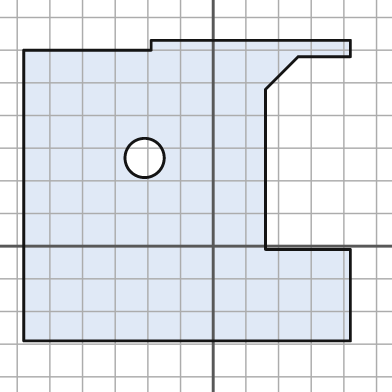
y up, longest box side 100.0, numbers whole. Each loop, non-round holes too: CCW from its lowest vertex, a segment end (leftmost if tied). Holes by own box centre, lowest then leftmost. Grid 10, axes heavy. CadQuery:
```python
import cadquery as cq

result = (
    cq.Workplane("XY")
    .moveTo(-58.0, -29.0)
    .lineTo(42.0, -29.0)
    .lineTo(42.0, -1.0)
    .lineTo(16.0, -1.0)
    .lineTo(16.0, 48.0)
    .lineTo(26.0, 58.0)
    .lineTo(42.0, 58.0)
    .lineTo(42.0, 63.0)
    .lineTo(-19.0, 63.0)
    .lineTo(-19.0, 60.0)
    .lineTo(-58.0, 60.0)
    .close()
    .moveTo(-21.0, 27.0)
    .circle(6.0)
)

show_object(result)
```